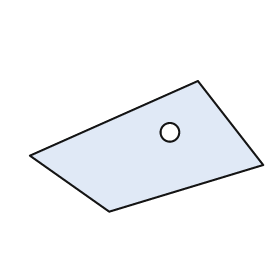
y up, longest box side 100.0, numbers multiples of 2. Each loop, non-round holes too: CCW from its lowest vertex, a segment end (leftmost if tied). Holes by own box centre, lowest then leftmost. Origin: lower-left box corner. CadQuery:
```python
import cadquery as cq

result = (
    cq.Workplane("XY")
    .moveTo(34.0, 0.0)
    .lineTo(100.0, 20.0)
    .lineTo(72.0, 56.0)
    .lineTo(0.0, 24.0)
    .close()
    .moveTo(60.0, 34.0)
    .circle(4.0)
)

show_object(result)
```